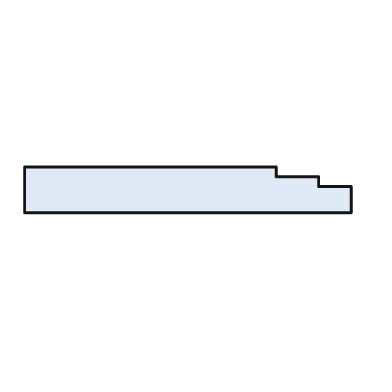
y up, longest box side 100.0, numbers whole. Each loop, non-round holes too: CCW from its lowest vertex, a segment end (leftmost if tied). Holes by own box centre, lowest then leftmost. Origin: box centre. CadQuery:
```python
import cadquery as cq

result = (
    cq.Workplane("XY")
    .moveTo(-50.0, -7.0)
    .lineTo(50.0, -7.0)
    .lineTo(50.0, 1.0)
    .lineTo(40.0, 1.0)
    .lineTo(40.0, 4.0)
    .lineTo(27.0, 4.0)
    .lineTo(27.0, 7.0)
    .lineTo(-50.0, 7.0)
    .close()
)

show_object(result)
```